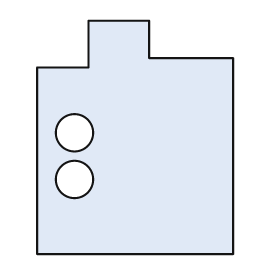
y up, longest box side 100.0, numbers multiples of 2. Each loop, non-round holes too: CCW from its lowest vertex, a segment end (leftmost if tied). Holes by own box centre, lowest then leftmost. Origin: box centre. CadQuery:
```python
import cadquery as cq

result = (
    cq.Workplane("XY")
    .moveTo(-42.0, -50.0)
    .lineTo(42.0, -50.0)
    .lineTo(42.0, 34.0)
    .lineTo(6.0, 34.0)
    .lineTo(6.0, 50.0)
    .lineTo(-20.0, 50.0)
    .lineTo(-20.0, 30.0)
    .lineTo(-42.0, 30.0)
    .close()
    .moveTo(-26.0, -18.0)
    .circle(8.0)
    .moveTo(-26.0, 2.0)
    .circle(8.0)
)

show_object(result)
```